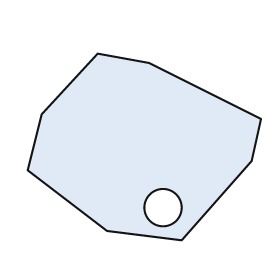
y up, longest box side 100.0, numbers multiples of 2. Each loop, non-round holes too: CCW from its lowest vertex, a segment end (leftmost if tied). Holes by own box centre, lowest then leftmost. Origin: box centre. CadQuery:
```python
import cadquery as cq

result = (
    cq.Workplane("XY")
    .moveTo(16.0, -40.0)
    .lineTo(46.0, -6.0)
    .lineTo(50.0, 12.0)
    .lineTo(2.0, 36.0)
    .lineTo(-20.0, 40.0)
    .lineTo(-44.0, 14.0)
    .lineTo(-50.0, -10.0)
    .lineTo(-16.0, -36.0)
    .close()
    .moveTo(8.0, -26.0)
    .circle(8.0)
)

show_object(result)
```